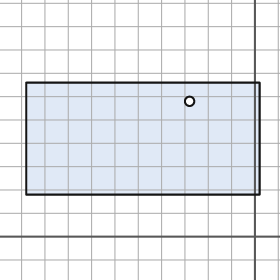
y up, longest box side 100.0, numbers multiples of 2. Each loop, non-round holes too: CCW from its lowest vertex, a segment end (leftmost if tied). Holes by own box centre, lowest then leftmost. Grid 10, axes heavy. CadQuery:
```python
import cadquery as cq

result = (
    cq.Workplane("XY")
    .moveTo(-98.0, 18.0)
    .lineTo(2.0, 18.0)
    .lineTo(2.0, 66.0)
    .lineTo(-98.0, 66.0)
    .close()
    .moveTo(-28.0, 58.0)
    .circle(2.0)
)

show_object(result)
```